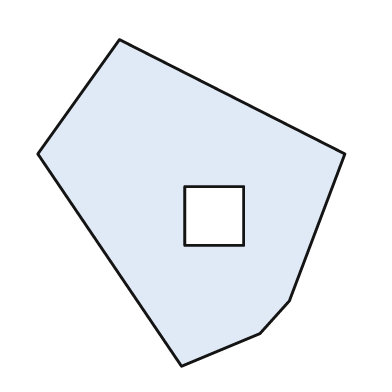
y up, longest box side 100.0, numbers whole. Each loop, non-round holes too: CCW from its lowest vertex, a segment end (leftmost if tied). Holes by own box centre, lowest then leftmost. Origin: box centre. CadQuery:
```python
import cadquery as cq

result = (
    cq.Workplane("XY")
    .moveTo(-3.0, -50.0)
    .lineTo(21.0, -40.0)
    .lineTo(30.0, -30.0)
    .lineTo(47.0, 15.0)
    .lineTo(-22.0, 50.0)
    .lineTo(-47.0, 15.0)
    .close()
    .moveTo(-2.0, -13.0)
    .lineTo(16.0, -13.0)
    .lineTo(16.0, 5.0)
    .lineTo(-2.0, 5.0)
    .close()
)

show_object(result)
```